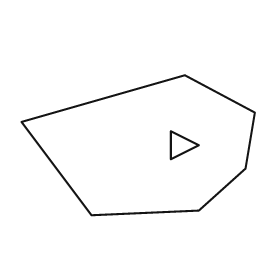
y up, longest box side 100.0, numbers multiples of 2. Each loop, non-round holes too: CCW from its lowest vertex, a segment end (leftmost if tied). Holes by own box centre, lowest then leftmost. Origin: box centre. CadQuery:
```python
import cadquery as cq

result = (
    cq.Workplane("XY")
    .moveTo(-20.0, -30.0)
    .lineTo(26.0, -28.0)
    .lineTo(46.0, -10.0)
    .lineTo(50.0, 14.0)
    .lineTo(20.0, 30.0)
    .lineTo(-50.0, 10.0)
    .close()
    .moveTo(14.0, -6.0)
    .lineTo(26.0, 0.0)
    .lineTo(14.0, 6.0)
    .close()
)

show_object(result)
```